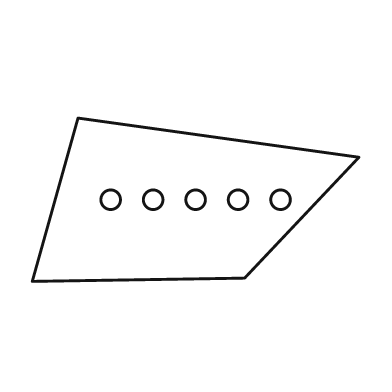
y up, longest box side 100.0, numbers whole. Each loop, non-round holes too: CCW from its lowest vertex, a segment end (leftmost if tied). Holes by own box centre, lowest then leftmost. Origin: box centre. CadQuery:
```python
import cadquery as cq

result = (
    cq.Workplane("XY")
    .moveTo(-50.0, -25.0)
    .lineTo(15.0, -24.0)
    .lineTo(50.0, 13.0)
    .lineTo(-36.0, 25.0)
    .close()
    .moveTo(-26.0, 0.0)
    .circle(3.0)
    .moveTo(-13.0, 0.0)
    .circle(3.0)
    .moveTo(0.0, 0.0)
    .circle(3.0)
    .moveTo(13.0, 0.0)
    .circle(3.0)
    .moveTo(26.0, 0.0)
    .circle(3.0)
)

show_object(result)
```